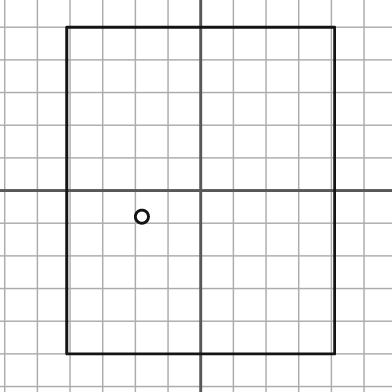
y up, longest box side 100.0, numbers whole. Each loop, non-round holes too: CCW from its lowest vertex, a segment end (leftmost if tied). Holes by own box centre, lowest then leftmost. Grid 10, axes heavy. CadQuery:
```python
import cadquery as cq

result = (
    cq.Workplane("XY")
    .moveTo(-41.0, -50.0)
    .lineTo(41.0, -50.0)
    .lineTo(41.0, 50.0)
    .lineTo(-41.0, 50.0)
    .close()
    .moveTo(-18.0, -8.0)
    .circle(2.0)
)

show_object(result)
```